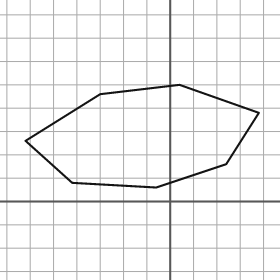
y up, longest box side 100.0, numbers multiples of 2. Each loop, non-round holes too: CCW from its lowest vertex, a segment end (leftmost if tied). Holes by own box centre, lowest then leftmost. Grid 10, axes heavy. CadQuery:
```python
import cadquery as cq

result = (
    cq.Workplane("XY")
    .moveTo(-6.0, 6.0)
    .lineTo(24.0, 16.0)
    .lineTo(38.0, 38.0)
    .lineTo(4.0, 50.0)
    .lineTo(-30.0, 46.0)
    .lineTo(-62.0, 26.0)
    .lineTo(-42.0, 8.0)
    .close()
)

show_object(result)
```